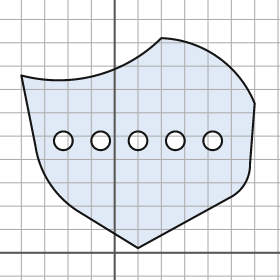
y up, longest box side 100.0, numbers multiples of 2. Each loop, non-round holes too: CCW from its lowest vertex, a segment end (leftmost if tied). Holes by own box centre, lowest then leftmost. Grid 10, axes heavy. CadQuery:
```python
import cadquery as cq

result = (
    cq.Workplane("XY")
    .moveTo(10.0, 2.0)
    .lineTo(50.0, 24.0)
    .threePointArc((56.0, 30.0), (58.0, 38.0))
    .lineTo(60.0, 64.0)
    .threePointArc((44.0, 84.0), (20.0, 92.0))
    .threePointArc((-8.0, 76.0), (-40.0, 76.0))
    .lineTo(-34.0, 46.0)
    .threePointArc((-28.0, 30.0), (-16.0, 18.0))
    .close()
    .moveTo(-22.0, 48.0)
    .circle(4.0)
    .moveTo(-6.0, 48.0)
    .circle(4.0)
    .moveTo(10.0, 48.0)
    .circle(4.0)
    .moveTo(26.0, 48.0)
    .circle(4.0)
    .moveTo(42.0, 48.0)
    .circle(4.0)
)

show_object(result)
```